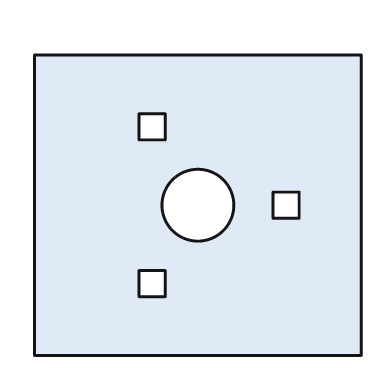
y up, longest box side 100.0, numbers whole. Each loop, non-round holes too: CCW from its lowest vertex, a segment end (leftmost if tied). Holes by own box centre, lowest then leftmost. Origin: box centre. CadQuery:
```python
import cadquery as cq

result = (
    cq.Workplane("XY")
    .moveTo(-50.0, -46.0)
    .lineTo(50.0, -46.0)
    .lineTo(50.0, 46.0)
    .lineTo(-50.0, 46.0)
    .close()
    .moveTo(-18.0, -28.0)
    .lineTo(-10.0, -28.0)
    .lineTo(-10.0, -20.0)
    .lineTo(-18.0, -20.0)
    .close()
    .moveTo(0.0, 0.0)
    .circle(11.0)
    .moveTo(23.0, -4.0)
    .lineTo(31.0, -4.0)
    .lineTo(31.0, 4.0)
    .lineTo(23.0, 4.0)
    .close()
    .moveTo(-18.0, 20.0)
    .lineTo(-10.0, 20.0)
    .lineTo(-10.0, 28.0)
    .lineTo(-18.0, 28.0)
    .close()
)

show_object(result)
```